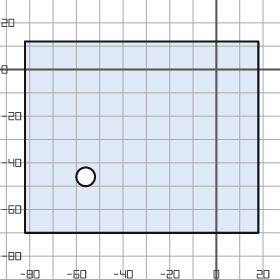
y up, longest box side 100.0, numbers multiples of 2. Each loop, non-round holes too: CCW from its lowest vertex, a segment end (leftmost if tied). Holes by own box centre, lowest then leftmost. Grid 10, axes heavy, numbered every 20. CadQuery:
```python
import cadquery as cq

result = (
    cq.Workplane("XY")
    .moveTo(-82.0, -70.0)
    .lineTo(18.0, -70.0)
    .lineTo(18.0, 12.0)
    .lineTo(-82.0, 12.0)
    .close()
    .moveTo(-56.0, -46.0)
    .circle(4.0)
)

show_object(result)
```